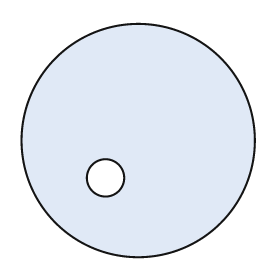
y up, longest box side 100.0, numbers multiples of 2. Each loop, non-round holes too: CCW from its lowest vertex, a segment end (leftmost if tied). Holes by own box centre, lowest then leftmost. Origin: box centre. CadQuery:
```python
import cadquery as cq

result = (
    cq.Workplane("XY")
    .moveTo(0.0, 0.0)
    .circle(50.0)
    .moveTo(-14.0, -16.0)
    .circle(8.0)
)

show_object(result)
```